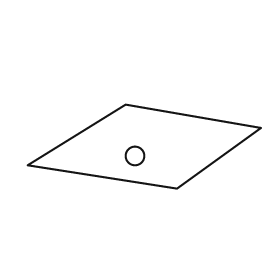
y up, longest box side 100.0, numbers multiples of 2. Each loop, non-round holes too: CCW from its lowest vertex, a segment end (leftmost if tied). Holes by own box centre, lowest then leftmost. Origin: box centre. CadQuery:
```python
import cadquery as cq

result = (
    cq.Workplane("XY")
    .moveTo(14.0, -18.0)
    .lineTo(50.0, 8.0)
    .lineTo(-8.0, 18.0)
    .lineTo(-50.0, -8.0)
    .close()
    .moveTo(-4.0, -4.0)
    .circle(4.0)
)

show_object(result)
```